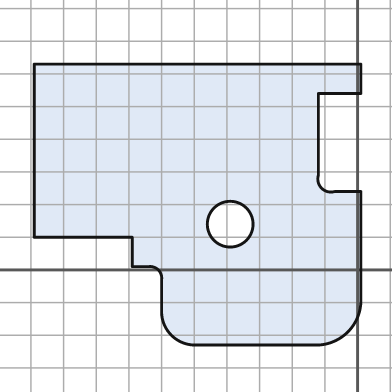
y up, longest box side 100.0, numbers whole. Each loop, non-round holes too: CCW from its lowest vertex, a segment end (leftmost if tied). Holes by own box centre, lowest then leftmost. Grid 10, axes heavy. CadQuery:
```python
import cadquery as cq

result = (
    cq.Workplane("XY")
    .moveTo(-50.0, -23.0)
    .lineTo(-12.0, -23.0)
    .threePointArc((-3.0, -19.0), (1.0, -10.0))
    .lineTo(1.0, 24.0)
    .lineTo(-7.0, 24.0)
    .threePointArc((-11.0, 25.0), (-12.0, 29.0))
    .lineTo(-12.0, 54.0)
    .lineTo(1.0, 54.0)
    .lineTo(1.0, 63.0)
    .lineTo(-99.0, 63.0)
    .lineTo(-99.0, 10.0)
    .lineTo(-69.0, 10.0)
    .lineTo(-69.0, 1.0)
    .lineTo(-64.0, 1.0)
    .threePointArc((-61.0, 0.0), (-60.0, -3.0))
    .lineTo(-60.0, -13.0)
    .threePointArc((-57.0, -20.0), (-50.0, -23.0))
    .close()
    .moveTo(-39.0, 14.0)
    .circle(7.0)
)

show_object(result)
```